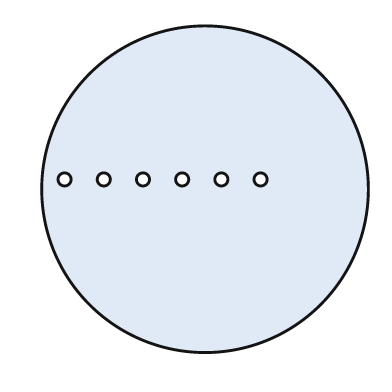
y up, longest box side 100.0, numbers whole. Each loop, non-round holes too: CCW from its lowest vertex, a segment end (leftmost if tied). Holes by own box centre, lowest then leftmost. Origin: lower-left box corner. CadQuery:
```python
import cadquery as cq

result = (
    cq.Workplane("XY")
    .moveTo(50.0, 50.0)
    .circle(50.0)
    .moveTo(7.0, 53.0)
    .circle(2.0)
    .moveTo(19.0, 53.0)
    .circle(2.0)
    .moveTo(31.0, 53.0)
    .circle(2.0)
    .moveTo(43.0, 53.0)
    .circle(2.0)
    .moveTo(55.0, 53.0)
    .circle(2.0)
    .moveTo(67.0, 53.0)
    .circle(2.0)
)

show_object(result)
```